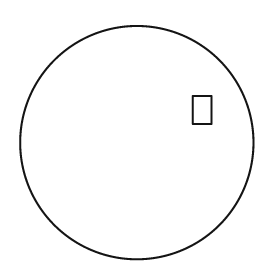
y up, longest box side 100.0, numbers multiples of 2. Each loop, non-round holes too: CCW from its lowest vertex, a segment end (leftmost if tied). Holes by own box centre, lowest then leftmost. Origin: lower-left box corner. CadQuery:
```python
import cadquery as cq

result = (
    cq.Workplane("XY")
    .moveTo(50.0, 50.0)
    .circle(50.0)
    .moveTo(74.0, 58.0)
    .lineTo(82.0, 58.0)
    .lineTo(82.0, 70.0)
    .lineTo(74.0, 70.0)
    .close()
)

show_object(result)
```